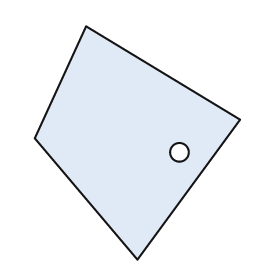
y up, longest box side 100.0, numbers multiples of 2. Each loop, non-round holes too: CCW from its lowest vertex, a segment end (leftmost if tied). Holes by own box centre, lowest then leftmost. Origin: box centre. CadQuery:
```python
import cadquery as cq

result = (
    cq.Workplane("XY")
    .moveTo(0.0, -50.0)
    .lineTo(44.0, 10.0)
    .lineTo(-22.0, 50.0)
    .lineTo(-44.0, 2.0)
    .close()
    .moveTo(18.0, -4.0)
    .circle(4.0)
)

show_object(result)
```